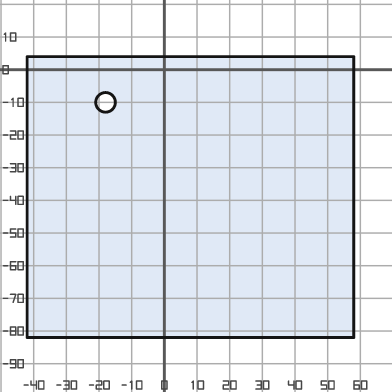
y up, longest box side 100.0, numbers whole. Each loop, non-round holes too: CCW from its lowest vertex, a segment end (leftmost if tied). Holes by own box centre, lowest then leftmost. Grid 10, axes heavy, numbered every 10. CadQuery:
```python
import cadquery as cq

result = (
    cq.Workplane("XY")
    .moveTo(-42.0, -82.0)
    .lineTo(58.0, -82.0)
    .lineTo(58.0, 4.0)
    .lineTo(-42.0, 4.0)
    .close()
    .moveTo(-18.0, -10.0)
    .circle(3.0)
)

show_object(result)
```